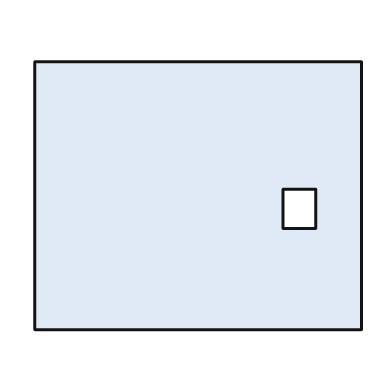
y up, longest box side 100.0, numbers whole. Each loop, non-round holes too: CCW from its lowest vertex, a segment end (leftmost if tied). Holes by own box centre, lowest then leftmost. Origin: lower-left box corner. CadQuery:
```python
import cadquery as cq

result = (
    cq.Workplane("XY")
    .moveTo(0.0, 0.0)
    .lineTo(100.0, 0.0)
    .lineTo(100.0, 82.0)
    .lineTo(0.0, 82.0)
    .close()
    .moveTo(76.0, 31.0)
    .lineTo(86.0, 31.0)
    .lineTo(86.0, 43.0)
    .lineTo(76.0, 43.0)
    .close()
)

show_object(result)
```